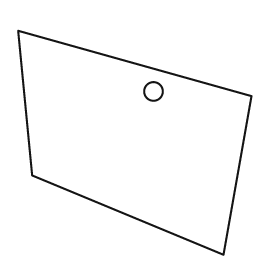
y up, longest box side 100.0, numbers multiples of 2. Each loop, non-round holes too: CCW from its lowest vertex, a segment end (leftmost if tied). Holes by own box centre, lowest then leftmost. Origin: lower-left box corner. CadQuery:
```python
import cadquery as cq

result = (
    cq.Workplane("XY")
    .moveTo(88.0, 0.0)
    .lineTo(100.0, 68.0)
    .lineTo(0.0, 96.0)
    .lineTo(6.0, 34.0)
    .close()
    .moveTo(58.0, 70.0)
    .circle(4.0)
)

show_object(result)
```